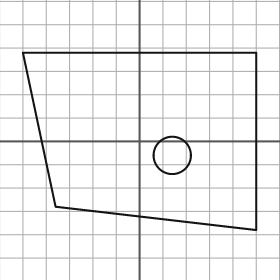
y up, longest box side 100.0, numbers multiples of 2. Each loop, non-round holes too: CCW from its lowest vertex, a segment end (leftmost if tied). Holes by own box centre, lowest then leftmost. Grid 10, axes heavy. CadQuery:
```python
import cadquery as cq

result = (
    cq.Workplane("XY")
    .moveTo(50.0, -38.0)
    .lineTo(50.0, 38.0)
    .lineTo(-50.0, 38.0)
    .lineTo(-36.0, -28.0)
    .close()
    .moveTo(14.0, -6.0)
    .circle(8.0)
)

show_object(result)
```